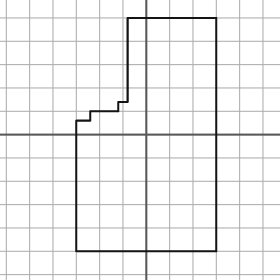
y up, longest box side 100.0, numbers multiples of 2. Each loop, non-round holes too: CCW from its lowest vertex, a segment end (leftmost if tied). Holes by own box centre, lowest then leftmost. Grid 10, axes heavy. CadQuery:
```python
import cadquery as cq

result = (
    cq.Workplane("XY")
    .moveTo(-30.0, -50.0)
    .lineTo(30.0, -50.0)
    .lineTo(30.0, 50.0)
    .lineTo(-8.0, 50.0)
    .lineTo(-8.0, 14.0)
    .lineTo(-12.0, 14.0)
    .lineTo(-12.0, 10.0)
    .lineTo(-24.0, 10.0)
    .lineTo(-24.0, 6.0)
    .lineTo(-30.0, 6.0)
    .close()
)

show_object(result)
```